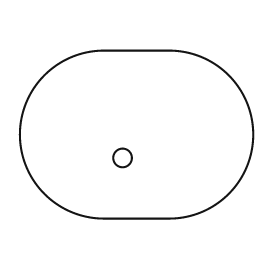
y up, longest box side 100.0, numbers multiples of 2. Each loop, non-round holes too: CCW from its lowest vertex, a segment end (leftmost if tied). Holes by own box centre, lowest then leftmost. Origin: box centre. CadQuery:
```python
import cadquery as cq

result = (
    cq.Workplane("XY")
    .moveTo(-14.0, -36.0)
    .lineTo(14.0, -36.0)
    .threePointArc((50.0, 0.0), (14.0, 36.0))
    .lineTo(-14.0, 36.0)
    .threePointArc((-50.0, 0.0), (-14.0, -36.0))
    .close()
    .moveTo(-6.0, -10.0)
    .circle(4.0)
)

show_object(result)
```